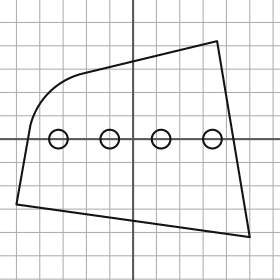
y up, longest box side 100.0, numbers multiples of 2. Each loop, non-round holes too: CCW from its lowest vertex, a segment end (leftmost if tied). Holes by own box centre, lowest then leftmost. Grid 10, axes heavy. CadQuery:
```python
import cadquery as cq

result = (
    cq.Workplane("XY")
    .moveTo(50.0, -42.0)
    .lineTo(36.0, 42.0)
    .lineTo(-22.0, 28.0)
    .threePointArc((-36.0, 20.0), (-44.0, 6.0))
    .lineTo(-50.0, -28.0)
    .close()
    .moveTo(-32.0, 0.0)
    .circle(4.0)
    .moveTo(-10.0, 0.0)
    .circle(4.0)
    .moveTo(12.0, 0.0)
    .circle(4.0)
    .moveTo(34.0, 0.0)
    .circle(4.0)
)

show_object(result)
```